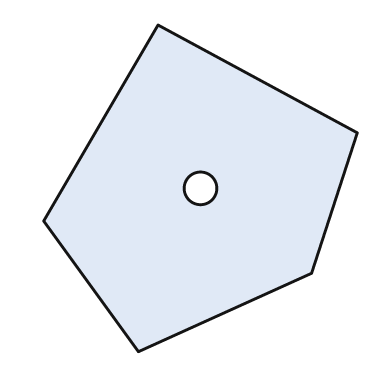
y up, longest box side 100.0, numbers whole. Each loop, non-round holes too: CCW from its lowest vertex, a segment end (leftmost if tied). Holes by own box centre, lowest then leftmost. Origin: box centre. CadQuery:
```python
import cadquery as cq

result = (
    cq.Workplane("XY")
    .moveTo(-19.0, -50.0)
    .lineTo(34.0, -26.0)
    .lineTo(48.0, 17.0)
    .lineTo(-13.0, 50.0)
    .lineTo(-48.0, -10.0)
    .close()
    .moveTo(0.0, 0.0)
    .circle(5.0)
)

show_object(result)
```